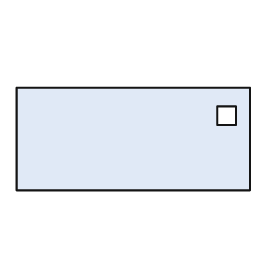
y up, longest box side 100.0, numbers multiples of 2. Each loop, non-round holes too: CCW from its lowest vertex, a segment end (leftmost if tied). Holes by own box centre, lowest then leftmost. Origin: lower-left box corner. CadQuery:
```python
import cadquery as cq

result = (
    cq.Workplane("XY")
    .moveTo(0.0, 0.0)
    .lineTo(100.0, 0.0)
    .lineTo(100.0, 44.0)
    .lineTo(0.0, 44.0)
    .close()
    .moveTo(86.0, 28.0)
    .lineTo(94.0, 28.0)
    .lineTo(94.0, 36.0)
    .lineTo(86.0, 36.0)
    .close()
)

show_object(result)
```